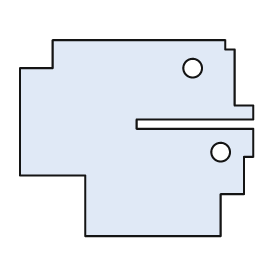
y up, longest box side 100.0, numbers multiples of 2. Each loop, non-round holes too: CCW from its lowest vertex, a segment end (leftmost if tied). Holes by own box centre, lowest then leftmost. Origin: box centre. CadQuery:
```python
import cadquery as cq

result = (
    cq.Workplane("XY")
    .moveTo(-22.0, -42.0)
    .lineTo(36.0, -42.0)
    .lineTo(36.0, -24.0)
    .lineTo(46.0, -24.0)
    .lineTo(46.0, -8.0)
    .lineTo(50.0, -8.0)
    .lineTo(50.0, 4.0)
    .lineTo(0.0, 4.0)
    .lineTo(0.0, 8.0)
    .lineTo(50.0, 8.0)
    .lineTo(50.0, 14.0)
    .lineTo(42.0, 14.0)
    .lineTo(42.0, 38.0)
    .lineTo(38.0, 38.0)
    .lineTo(38.0, 42.0)
    .lineTo(-36.0, 42.0)
    .lineTo(-36.0, 30.0)
    .lineTo(-50.0, 30.0)
    .lineTo(-50.0, -16.0)
    .lineTo(-22.0, -16.0)
    .close()
    .moveTo(36.0, -6.0)
    .circle(4.0)
    .moveTo(24.0, 30.0)
    .circle(4.0)
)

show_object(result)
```